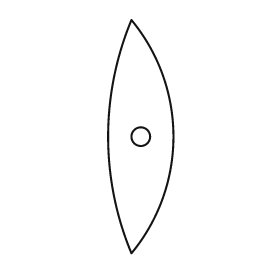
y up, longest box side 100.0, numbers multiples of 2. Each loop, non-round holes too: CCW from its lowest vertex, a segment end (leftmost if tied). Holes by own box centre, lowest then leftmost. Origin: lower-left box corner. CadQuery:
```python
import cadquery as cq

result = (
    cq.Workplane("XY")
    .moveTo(10.0, 0.0)
    .threePointArc((28.0, 50.0), (10.0, 100.0))
    .threePointArc((0.0, 50.0), (10.0, 0.0))
    .close()
    .moveTo(14.0, 50.0)
    .circle(4.0)
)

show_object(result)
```